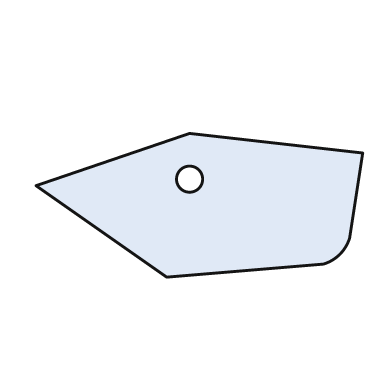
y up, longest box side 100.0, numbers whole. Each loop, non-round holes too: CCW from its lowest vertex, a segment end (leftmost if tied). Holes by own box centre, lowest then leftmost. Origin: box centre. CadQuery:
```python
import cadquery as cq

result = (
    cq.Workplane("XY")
    .moveTo(-10.0, -22.0)
    .lineTo(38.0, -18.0)
    .threePointArc((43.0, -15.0), (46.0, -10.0))
    .lineTo(50.0, 16.0)
    .lineTo(-3.0, 22.0)
    .lineTo(-50.0, 6.0)
    .close()
    .moveTo(-3.0, 8.0)
    .circle(4.0)
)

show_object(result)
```